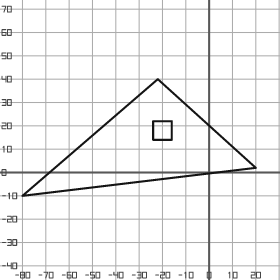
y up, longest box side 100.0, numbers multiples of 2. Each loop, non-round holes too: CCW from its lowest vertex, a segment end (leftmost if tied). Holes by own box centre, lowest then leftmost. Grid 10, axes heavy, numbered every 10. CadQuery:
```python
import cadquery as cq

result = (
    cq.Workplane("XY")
    .moveTo(-80.0, -10.0)
    .lineTo(20.0, 2.0)
    .lineTo(-22.0, 40.0)
    .close()
    .moveTo(-24.0, 14.0)
    .lineTo(-16.0, 14.0)
    .lineTo(-16.0, 22.0)
    .lineTo(-24.0, 22.0)
    .close()
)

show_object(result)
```